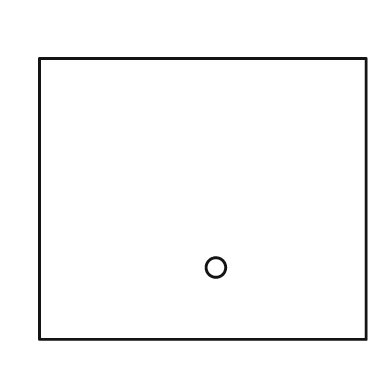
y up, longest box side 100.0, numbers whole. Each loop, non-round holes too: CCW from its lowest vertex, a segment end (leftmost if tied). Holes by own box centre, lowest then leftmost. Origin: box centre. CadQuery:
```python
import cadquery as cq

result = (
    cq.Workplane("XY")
    .moveTo(-50.0, -43.0)
    .lineTo(50.0, -43.0)
    .lineTo(50.0, 43.0)
    .lineTo(-50.0, 43.0)
    .close()
    .moveTo(4.0, -21.0)
    .circle(3.0)
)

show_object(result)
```